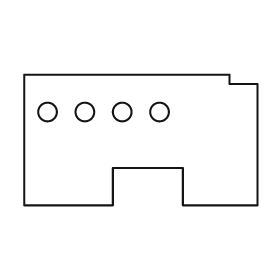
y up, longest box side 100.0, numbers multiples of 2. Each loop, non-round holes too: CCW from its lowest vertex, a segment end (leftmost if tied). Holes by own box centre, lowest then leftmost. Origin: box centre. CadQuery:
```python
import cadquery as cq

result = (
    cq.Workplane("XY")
    .moveTo(-50.0, -28.0)
    .lineTo(-12.0, -28.0)
    .lineTo(-12.0, -12.0)
    .lineTo(18.0, -12.0)
    .lineTo(18.0, -28.0)
    .lineTo(50.0, -28.0)
    .lineTo(50.0, 24.0)
    .lineTo(38.0, 24.0)
    .lineTo(38.0, 28.0)
    .lineTo(-50.0, 28.0)
    .close()
    .moveTo(-40.0, 12.0)
    .circle(4.0)
    .moveTo(-24.0, 12.0)
    .circle(4.0)
    .moveTo(-8.0, 12.0)
    .circle(4.0)
    .moveTo(8.0, 12.0)
    .circle(4.0)
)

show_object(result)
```